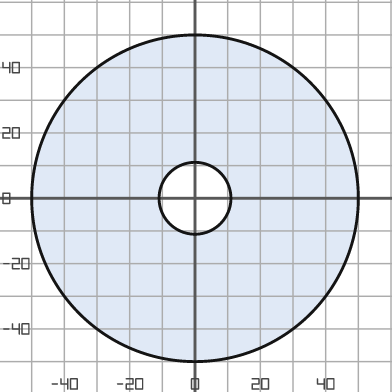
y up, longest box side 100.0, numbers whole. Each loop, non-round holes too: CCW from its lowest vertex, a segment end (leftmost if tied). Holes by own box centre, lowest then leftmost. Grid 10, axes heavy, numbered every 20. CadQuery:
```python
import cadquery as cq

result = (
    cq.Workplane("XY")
    .moveTo(0.0, 0.0)
    .circle(50.0)
    .moveTo(0.0, 0.0)
    .circle(11.0)
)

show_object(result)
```